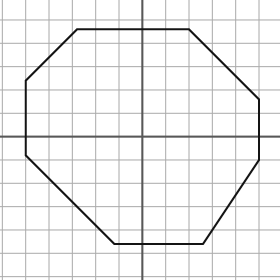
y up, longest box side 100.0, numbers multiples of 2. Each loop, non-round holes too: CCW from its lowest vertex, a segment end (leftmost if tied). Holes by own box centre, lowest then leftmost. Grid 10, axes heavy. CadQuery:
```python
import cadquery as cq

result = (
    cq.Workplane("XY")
    .moveTo(-12.0, -46.0)
    .lineTo(26.0, -46.0)
    .lineTo(50.0, -10.0)
    .lineTo(50.0, 16.0)
    .lineTo(20.0, 46.0)
    .lineTo(-28.0, 46.0)
    .lineTo(-50.0, 24.0)
    .lineTo(-50.0, -8.0)
    .close()
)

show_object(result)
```